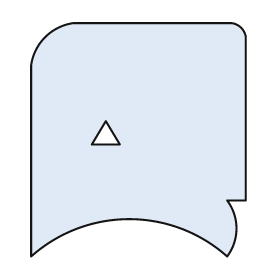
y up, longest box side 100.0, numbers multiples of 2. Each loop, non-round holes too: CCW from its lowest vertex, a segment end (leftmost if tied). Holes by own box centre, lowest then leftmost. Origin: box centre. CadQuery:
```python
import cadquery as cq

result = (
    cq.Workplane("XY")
    .moveTo(-46.0, -50.0)
    .threePointArc((-4.0, -34.0), (38.0, -50.0))
    .threePointArc((42.0, -38.0), (38.0, -26.0))
    .lineTo(46.0, -26.0)
    .lineTo(46.0, 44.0)
    .threePointArc((44.0, 48.0), (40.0, 50.0))
    .lineTo(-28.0, 50.0)
    .threePointArc((-40.0, 44.0), (-46.0, 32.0))
    .close()
    .moveTo(-20.0, -2.0)
    .lineTo(-8.0, -2.0)
    .lineTo(-14.0, 8.0)
    .close()
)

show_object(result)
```